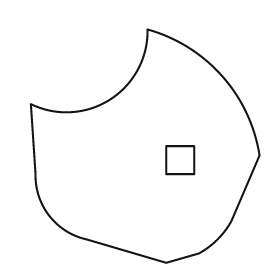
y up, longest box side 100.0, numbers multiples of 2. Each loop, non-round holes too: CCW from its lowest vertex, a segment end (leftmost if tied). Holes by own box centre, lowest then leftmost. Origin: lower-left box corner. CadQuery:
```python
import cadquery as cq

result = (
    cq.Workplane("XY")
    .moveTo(58.0, 0.0)
    .lineTo(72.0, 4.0)
    .threePointArc((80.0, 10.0), (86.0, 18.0))
    .lineTo(98.0, 46.0)
    .threePointArc((82.0, 80.0), (50.0, 100.0))
    .threePointArc((34.0, 70.0), (0.0, 68.0))
    .lineTo(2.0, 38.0)
    .threePointArc((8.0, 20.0), (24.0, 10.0))
    .close()
    .moveTo(58.0, 38.0)
    .lineTo(70.0, 38.0)
    .lineTo(70.0, 50.0)
    .lineTo(58.0, 50.0)
    .close()
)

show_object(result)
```